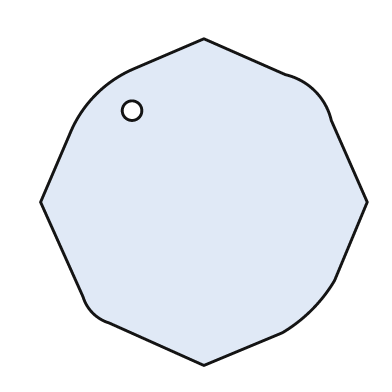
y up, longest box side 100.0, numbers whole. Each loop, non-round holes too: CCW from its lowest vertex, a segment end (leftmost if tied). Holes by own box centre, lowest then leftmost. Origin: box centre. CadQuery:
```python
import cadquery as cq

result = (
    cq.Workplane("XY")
    .moveTo(0.0, -50.0)
    .lineTo(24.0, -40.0)
    .threePointArc((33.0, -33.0), (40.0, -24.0))
    .lineTo(50.0, 0.0)
    .lineTo(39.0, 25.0)
    .threePointArc((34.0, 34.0), (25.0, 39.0))
    .lineTo(0.0, 50.0)
    .lineTo(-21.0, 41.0)
    .threePointArc((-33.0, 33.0), (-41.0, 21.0))
    .lineTo(-50.0, 0.0)
    .lineTo(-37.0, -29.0)
    .threePointArc((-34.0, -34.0), (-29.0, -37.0))
    .close()
    .moveTo(-22.0, 28.0)
    .circle(3.0)
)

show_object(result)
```